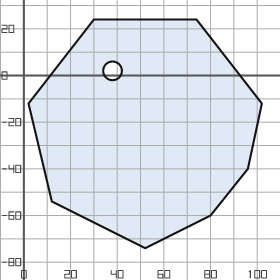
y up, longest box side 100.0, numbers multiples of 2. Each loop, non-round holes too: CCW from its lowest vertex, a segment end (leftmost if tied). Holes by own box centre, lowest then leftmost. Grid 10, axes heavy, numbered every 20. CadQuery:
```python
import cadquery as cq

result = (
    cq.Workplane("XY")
    .moveTo(52.0, -74.0)
    .lineTo(80.0, -60.0)
    .lineTo(96.0, -40.0)
    .lineTo(102.0, -12.0)
    .lineTo(74.0, 24.0)
    .lineTo(30.0, 24.0)
    .lineTo(2.0, -12.0)
    .lineTo(12.0, -54.0)
    .close()
    .moveTo(38.0, 2.0)
    .circle(4.0)
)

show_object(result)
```